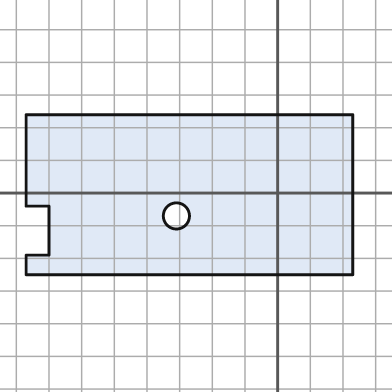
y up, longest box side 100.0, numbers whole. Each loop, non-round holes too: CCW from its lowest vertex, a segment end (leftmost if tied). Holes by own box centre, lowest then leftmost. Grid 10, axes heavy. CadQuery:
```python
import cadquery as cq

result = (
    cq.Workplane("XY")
    .moveTo(-77.0, -25.0)
    .lineTo(23.0, -25.0)
    .lineTo(23.0, 24.0)
    .lineTo(-77.0, 24.0)
    .lineTo(-77.0, -4.0)
    .lineTo(-70.0, -4.0)
    .lineTo(-70.0, -19.0)
    .lineTo(-77.0, -19.0)
    .close()
    .moveTo(-31.0, -7.0)
    .circle(4.0)
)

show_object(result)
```